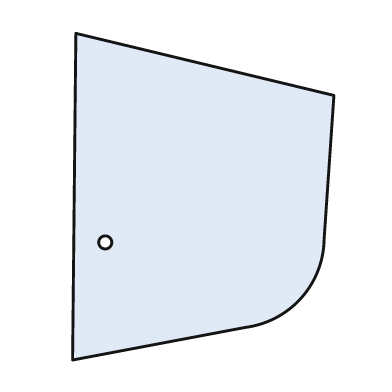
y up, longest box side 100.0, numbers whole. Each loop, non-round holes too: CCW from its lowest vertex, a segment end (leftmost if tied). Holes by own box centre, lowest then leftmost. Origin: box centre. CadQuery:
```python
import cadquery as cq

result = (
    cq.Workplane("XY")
    .moveTo(-40.0, -50.0)
    .lineTo(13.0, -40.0)
    .threePointArc((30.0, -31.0), (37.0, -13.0))
    .lineTo(40.0, 31.0)
    .lineTo(-39.0, 50.0)
    .close()
    .moveTo(-30.0, -14.0)
    .circle(2.0)
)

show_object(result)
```